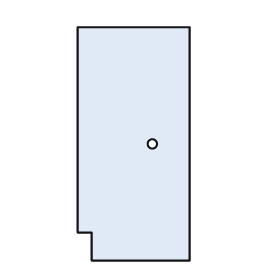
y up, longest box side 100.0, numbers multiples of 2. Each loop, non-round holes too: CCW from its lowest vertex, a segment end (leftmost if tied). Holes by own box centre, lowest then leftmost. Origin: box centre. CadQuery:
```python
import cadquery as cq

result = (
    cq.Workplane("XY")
    .moveTo(-18.0, -50.0)
    .lineTo(24.0, -50.0)
    .lineTo(24.0, 50.0)
    .lineTo(-24.0, 50.0)
    .lineTo(-24.0, -38.0)
    .lineTo(-18.0, -38.0)
    .close()
    .moveTo(8.0, 0.0)
    .circle(2.0)
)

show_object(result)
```